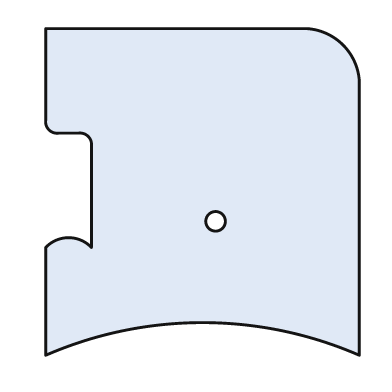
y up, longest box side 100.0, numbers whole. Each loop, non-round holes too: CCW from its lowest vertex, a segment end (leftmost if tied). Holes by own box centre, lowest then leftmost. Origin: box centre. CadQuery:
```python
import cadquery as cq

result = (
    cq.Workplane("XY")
    .moveTo(-48.0, -50.0)
    .threePointArc((0.0, -40.0), (48.0, -50.0))
    .lineTo(48.0, 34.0)
    .threePointArc((43.0, 45.0), (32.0, 50.0))
    .lineTo(-48.0, 50.0)
    .lineTo(-48.0, 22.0)
    .threePointArc((-47.0, 19.0), (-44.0, 18.0))
    .lineTo(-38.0, 18.0)
    .threePointArc((-35.0, 17.0), (-34.0, 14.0))
    .lineTo(-34.0, -17.0)
    .threePointArc((-41.0, -14.0), (-48.0, -17.0))
    .close()
    .moveTo(4.0, -9.0)
    .circle(3.0)
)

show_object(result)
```